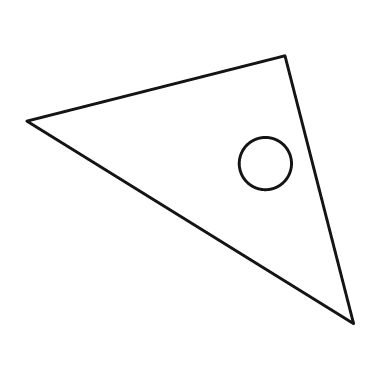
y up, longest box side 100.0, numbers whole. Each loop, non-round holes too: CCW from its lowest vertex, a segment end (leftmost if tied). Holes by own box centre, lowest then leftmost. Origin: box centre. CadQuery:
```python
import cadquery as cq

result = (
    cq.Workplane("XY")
    .moveTo(50.0, -41.0)
    .lineTo(29.0, 41.0)
    .lineTo(-50.0, 21.0)
    .close()
    .moveTo(23.0, 8.0)
    .circle(8.0)
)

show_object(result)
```